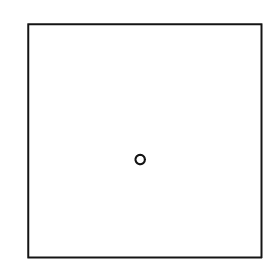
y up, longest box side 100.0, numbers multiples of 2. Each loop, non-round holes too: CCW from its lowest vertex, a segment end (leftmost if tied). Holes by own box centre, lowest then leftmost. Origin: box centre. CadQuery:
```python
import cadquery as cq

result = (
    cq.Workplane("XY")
    .moveTo(-50.0, -50.0)
    .lineTo(50.0, -50.0)
    .lineTo(50.0, 50.0)
    .lineTo(-50.0, 50.0)
    .close()
    .moveTo(-2.0, -8.0)
    .circle(2.0)
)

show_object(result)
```